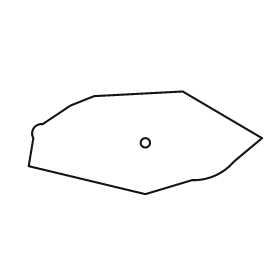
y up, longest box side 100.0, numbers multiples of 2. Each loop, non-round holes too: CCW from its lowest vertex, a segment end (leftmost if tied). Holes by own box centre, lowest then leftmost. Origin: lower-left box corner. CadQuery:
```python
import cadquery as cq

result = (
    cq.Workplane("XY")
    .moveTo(50.0, 0.0)
    .lineTo(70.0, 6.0)
    .threePointArc((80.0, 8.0), (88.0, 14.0))
    .lineTo(100.0, 24.0)
    .lineTo(66.0, 44.0)
    .lineTo(28.0, 42.0)
    .lineTo(18.0, 38.0)
    .lineTo(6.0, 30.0)
    .threePointArc((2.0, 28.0), (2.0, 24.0))
    .lineTo(0.0, 12.0)
    .close()
    .moveTo(50.0, 22.0)
    .circle(2.0)
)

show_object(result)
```